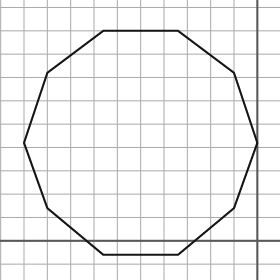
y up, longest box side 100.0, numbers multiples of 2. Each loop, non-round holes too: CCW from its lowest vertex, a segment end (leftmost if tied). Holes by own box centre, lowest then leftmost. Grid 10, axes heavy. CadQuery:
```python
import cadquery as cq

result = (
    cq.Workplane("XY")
    .moveTo(-66.0, -6.0)
    .lineTo(-34.0, -6.0)
    .lineTo(-10.0, 14.0)
    .lineTo(0.0, 42.0)
    .lineTo(-10.0, 72.0)
    .lineTo(-34.0, 90.0)
    .lineTo(-66.0, 90.0)
    .lineTo(-90.0, 72.0)
    .lineTo(-100.0, 42.0)
    .lineTo(-90.0, 14.0)
    .close()
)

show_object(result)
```